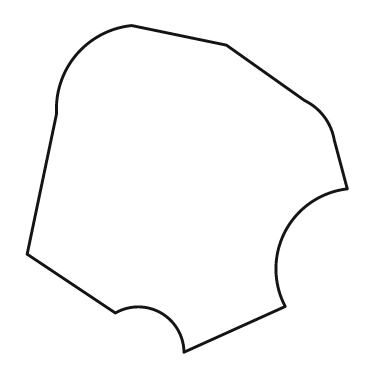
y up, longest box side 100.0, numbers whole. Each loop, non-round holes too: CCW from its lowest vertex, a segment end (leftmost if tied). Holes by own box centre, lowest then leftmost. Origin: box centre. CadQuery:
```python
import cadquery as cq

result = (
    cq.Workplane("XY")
    .moveTo(-1.0, -50.0)
    .lineTo(30.0, -36.0)
    .threePointArc((30.0, -13.0), (49.0, 0.0))
    .lineTo(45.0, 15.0)
    .threePointArc((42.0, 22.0), (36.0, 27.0))
    .lineTo(12.0, 44.0)
    .lineTo(-17.0, 50.0)
    .threePointArc((-34.0, 41.0), (-40.0, 23.0))
    .lineTo(-49.0, -20.0)
    .lineTo(-22.0, -38.0)
    .threePointArc((-8.0, -38.0), (-1.0, -50.0))
    .close()
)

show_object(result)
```